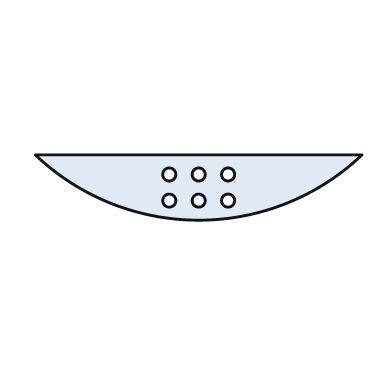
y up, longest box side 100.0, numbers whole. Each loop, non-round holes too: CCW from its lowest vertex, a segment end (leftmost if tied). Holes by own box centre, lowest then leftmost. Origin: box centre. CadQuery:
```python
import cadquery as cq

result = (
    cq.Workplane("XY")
    .moveTo(-50.0, 10.0)
    .threePointArc((0.0, -10.0), (50.0, 10.0))
    .close()
    .moveTo(-9.0, -4.0)
    .circle(2.0)
    .moveTo(0.0, -4.0)
    .circle(2.0)
    .moveTo(9.0, -4.0)
    .circle(2.0)
    .moveTo(-9.0, 4.0)
    .circle(2.0)
    .moveTo(0.0, 4.0)
    .circle(2.0)
    .moveTo(9.0, 4.0)
    .circle(2.0)
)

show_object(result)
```